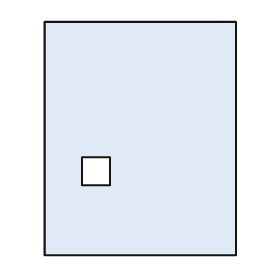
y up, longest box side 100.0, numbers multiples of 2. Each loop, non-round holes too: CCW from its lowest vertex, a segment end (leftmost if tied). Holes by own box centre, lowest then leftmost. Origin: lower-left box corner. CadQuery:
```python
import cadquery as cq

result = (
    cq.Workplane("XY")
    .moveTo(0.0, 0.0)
    .lineTo(82.0, 0.0)
    .lineTo(82.0, 100.0)
    .lineTo(0.0, 100.0)
    .close()
    .moveTo(16.0, 30.0)
    .lineTo(28.0, 30.0)
    .lineTo(28.0, 42.0)
    .lineTo(16.0, 42.0)
    .close()
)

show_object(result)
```